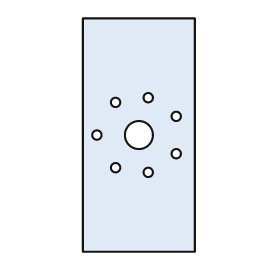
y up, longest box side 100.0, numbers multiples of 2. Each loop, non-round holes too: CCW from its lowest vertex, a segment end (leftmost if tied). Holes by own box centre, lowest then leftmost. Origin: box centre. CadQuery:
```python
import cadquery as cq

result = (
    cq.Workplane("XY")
    .moveTo(-24.0, -50.0)
    .lineTo(24.0, -50.0)
    .lineTo(24.0, 50.0)
    .lineTo(-24.0, 50.0)
    .close()
    .moveTo(4.0, -16.0)
    .circle(2.0)
    .moveTo(-10.0, -14.0)
    .circle(2.0)
    .moveTo(16.0, -8.0)
    .circle(2.0)
    .moveTo(-18.0, 0.0)
    .circle(2.0)
    .moveTo(0.0, 0.0)
    .circle(6.0)
    .moveTo(16.0, 8.0)
    .circle(2.0)
    .moveTo(-10.0, 14.0)
    .circle(2.0)
    .moveTo(4.0, 16.0)
    .circle(2.0)
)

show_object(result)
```